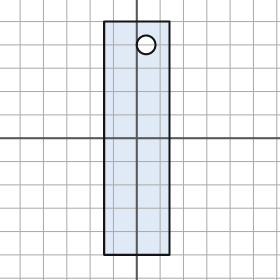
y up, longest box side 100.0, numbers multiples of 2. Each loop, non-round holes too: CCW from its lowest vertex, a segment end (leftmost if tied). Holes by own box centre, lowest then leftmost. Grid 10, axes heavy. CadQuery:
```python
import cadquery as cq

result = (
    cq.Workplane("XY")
    .moveTo(-14.0, -50.0)
    .lineTo(14.0, -50.0)
    .lineTo(14.0, 50.0)
    .lineTo(-14.0, 50.0)
    .close()
    .moveTo(4.0, 40.0)
    .circle(4.0)
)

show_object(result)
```